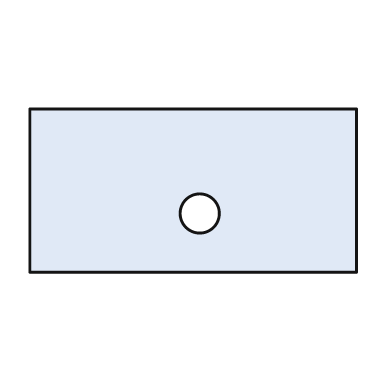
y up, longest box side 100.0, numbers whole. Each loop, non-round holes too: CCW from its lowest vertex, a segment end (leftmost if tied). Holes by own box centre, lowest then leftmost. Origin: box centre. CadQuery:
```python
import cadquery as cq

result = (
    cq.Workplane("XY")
    .moveTo(-50.0, -25.0)
    .lineTo(50.0, -25.0)
    .lineTo(50.0, 25.0)
    .lineTo(-50.0, 25.0)
    .close()
    .moveTo(2.0, -7.0)
    .circle(6.0)
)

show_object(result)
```